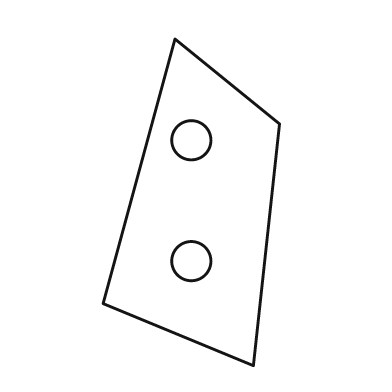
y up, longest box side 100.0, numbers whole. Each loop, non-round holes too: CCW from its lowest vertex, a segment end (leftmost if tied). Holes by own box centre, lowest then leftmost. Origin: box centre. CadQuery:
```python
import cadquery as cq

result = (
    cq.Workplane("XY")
    .moveTo(19.0, -50.0)
    .lineTo(27.0, 24.0)
    .lineTo(-5.0, 50.0)
    .lineTo(-27.0, -31.0)
    .close()
    .moveTo(0.0, -18.0)
    .circle(6.0)
    .moveTo(0.0, 19.0)
    .circle(6.0)
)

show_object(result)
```